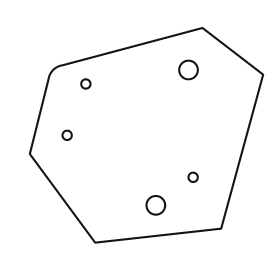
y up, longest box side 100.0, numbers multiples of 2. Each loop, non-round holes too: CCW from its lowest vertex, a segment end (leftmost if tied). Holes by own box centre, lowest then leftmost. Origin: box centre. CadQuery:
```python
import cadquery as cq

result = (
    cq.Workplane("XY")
    .moveTo(-22.0, -46.0)
    .lineTo(32.0, -40.0)
    .lineTo(50.0, 26.0)
    .lineTo(24.0, 46.0)
    .lineTo(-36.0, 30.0)
    .threePointArc((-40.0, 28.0), (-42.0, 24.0))
    .lineTo(-50.0, -8.0)
    .close()
    .moveTo(4.0, -30.0)
    .circle(4.0)
    .moveTo(20.0, -18.0)
    .circle(2.0)
    .moveTo(-34.0, 0.0)
    .circle(2.0)
    .moveTo(-26.0, 22.0)
    .circle(2.0)
    .moveTo(18.0, 28.0)
    .circle(4.0)
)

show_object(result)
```